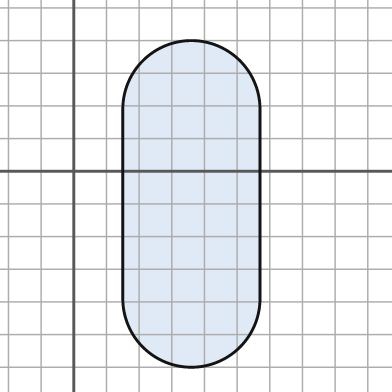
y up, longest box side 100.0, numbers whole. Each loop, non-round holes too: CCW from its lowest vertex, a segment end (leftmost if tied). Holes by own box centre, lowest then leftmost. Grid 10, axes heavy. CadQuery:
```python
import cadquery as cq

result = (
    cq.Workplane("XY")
    .moveTo(15.0, -39.0)
    .threePointArc((36.0, -60.0), (57.0, -39.0))
    .lineTo(57.0, 19.0)
    .threePointArc((36.0, 40.0), (15.0, 19.0))
    .close()
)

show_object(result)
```